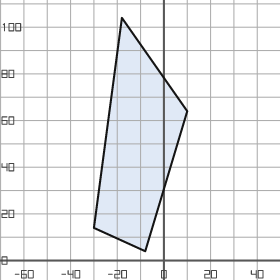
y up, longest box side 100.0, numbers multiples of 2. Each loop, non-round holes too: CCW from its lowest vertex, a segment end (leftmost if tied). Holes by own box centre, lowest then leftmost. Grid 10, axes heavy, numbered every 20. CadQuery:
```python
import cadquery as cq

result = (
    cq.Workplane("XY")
    .moveTo(-8.0, 4.0)
    .lineTo(10.0, 64.0)
    .lineTo(-18.0, 104.0)
    .lineTo(-30.0, 14.0)
    .close()
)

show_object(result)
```